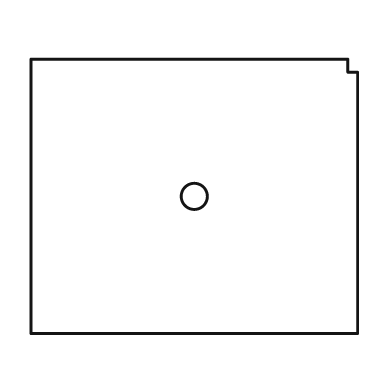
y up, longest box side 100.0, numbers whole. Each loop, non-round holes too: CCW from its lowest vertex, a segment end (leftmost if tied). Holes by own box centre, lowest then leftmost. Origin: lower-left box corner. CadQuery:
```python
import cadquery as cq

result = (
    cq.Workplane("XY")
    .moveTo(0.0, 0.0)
    .lineTo(100.0, 0.0)
    .lineTo(100.0, 80.0)
    .lineTo(97.0, 80.0)
    .lineTo(97.0, 84.0)
    .lineTo(0.0, 84.0)
    .close()
    .moveTo(50.0, 42.0)
    .circle(4.0)
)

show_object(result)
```